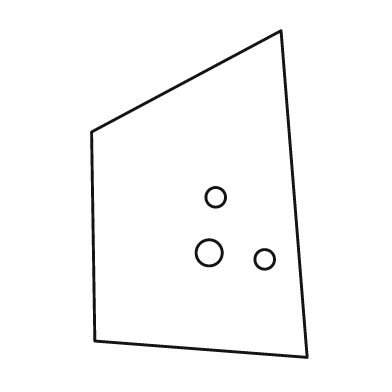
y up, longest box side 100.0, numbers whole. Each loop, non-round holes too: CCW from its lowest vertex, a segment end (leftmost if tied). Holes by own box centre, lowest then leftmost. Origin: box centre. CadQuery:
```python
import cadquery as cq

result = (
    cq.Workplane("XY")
    .moveTo(33.0, -50.0)
    .lineTo(25.0, 50.0)
    .lineTo(-33.0, 19.0)
    .lineTo(-32.0, -45.0)
    .close()
    .moveTo(20.0, -20.0)
    .circle(3.0)
    .moveTo(3.0, -18.0)
    .circle(4.0)
    .moveTo(5.0, -1.0)
    .circle(3.0)
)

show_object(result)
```